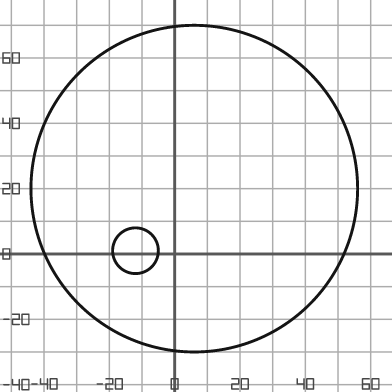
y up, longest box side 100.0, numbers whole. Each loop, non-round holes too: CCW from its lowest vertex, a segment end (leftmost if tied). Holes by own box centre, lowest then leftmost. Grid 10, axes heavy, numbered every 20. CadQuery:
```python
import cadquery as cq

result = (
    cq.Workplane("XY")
    .moveTo(6.0, 20.0)
    .circle(50.0)
    .moveTo(-12.0, 1.0)
    .circle(7.0)
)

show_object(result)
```